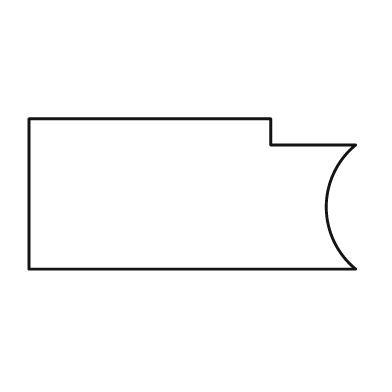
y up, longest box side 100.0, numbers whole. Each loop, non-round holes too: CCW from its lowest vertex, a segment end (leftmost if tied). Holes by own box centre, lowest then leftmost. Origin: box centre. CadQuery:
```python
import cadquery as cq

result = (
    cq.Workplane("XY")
    .moveTo(-50.0, -23.0)
    .lineTo(50.0, -23.0)
    .threePointArc((41.0, -4.0), (50.0, 15.0))
    .lineTo(24.0, 15.0)
    .lineTo(24.0, 23.0)
    .lineTo(-50.0, 23.0)
    .close()
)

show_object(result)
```